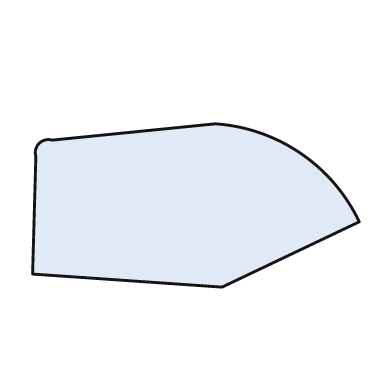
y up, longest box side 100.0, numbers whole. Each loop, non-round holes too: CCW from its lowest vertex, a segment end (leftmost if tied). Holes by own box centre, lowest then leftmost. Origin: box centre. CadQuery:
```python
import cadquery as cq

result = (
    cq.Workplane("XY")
    .moveTo(8.0, -25.0)
    .lineTo(50.0, -5.0)
    .threePointArc((32.0, 16.0), (6.0, 25.0))
    .lineTo(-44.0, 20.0)
    .threePointArc((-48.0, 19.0), (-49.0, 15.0))
    .lineTo(-50.0, -21.0)
    .close()
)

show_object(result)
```